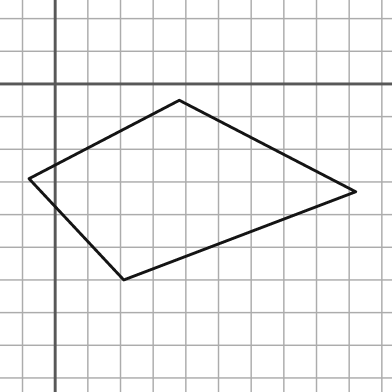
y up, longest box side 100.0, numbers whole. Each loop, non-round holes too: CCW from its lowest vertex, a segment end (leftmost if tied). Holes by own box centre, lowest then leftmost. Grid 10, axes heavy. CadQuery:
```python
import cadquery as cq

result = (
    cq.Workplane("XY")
    .moveTo(21.0, -60.0)
    .lineTo(92.0, -33.0)
    .lineTo(38.0, -5.0)
    .lineTo(-8.0, -29.0)
    .close()
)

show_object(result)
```